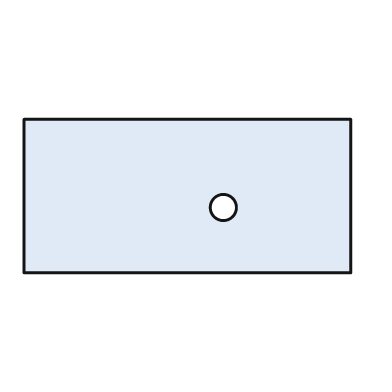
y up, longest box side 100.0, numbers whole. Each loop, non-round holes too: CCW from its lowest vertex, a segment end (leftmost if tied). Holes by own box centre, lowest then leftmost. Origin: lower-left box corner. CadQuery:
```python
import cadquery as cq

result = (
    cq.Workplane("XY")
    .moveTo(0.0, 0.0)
    .lineTo(100.0, 0.0)
    .lineTo(100.0, 47.0)
    .lineTo(0.0, 47.0)
    .close()
    .moveTo(61.0, 20.0)
    .circle(4.0)
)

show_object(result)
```